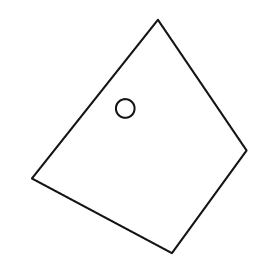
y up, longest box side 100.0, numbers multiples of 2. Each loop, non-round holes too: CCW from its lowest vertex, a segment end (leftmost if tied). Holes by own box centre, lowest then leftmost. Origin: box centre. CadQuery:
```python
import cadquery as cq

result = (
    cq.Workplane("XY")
    .moveTo(14.0, -50.0)
    .lineTo(46.0, -6.0)
    .lineTo(8.0, 50.0)
    .lineTo(-46.0, -18.0)
    .close()
    .moveTo(-6.0, 12.0)
    .circle(4.0)
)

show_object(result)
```